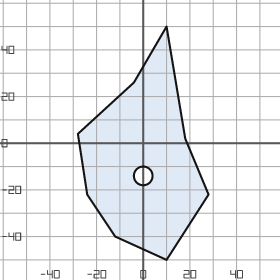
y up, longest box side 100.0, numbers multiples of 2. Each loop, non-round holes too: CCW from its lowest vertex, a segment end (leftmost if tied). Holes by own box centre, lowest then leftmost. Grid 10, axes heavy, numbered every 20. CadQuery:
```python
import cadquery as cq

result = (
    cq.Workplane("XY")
    .moveTo(10.0, -50.0)
    .lineTo(28.0, -22.0)
    .lineTo(18.0, 2.0)
    .lineTo(10.0, 50.0)
    .lineTo(-4.0, 26.0)
    .lineTo(-28.0, 4.0)
    .lineTo(-24.0, -22.0)
    .lineTo(-12.0, -40.0)
    .close()
    .moveTo(0.0, -14.0)
    .circle(4.0)
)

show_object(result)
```